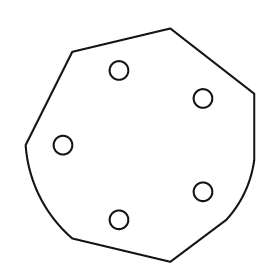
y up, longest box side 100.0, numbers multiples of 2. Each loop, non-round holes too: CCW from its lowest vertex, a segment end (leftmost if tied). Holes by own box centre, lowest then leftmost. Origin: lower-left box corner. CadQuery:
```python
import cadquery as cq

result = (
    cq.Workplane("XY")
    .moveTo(62.0, 0.0)
    .lineTo(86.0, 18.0)
    .threePointArc((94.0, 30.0), (98.0, 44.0))
    .lineTo(98.0, 72.0)
    .lineTo(62.0, 100.0)
    .lineTo(20.0, 90.0)
    .lineTo(0.0, 50.0)
    .threePointArc((6.0, 28.0), (20.0, 10.0))
    .close()
    .moveTo(40.0, 18.0)
    .circle(4.0)
    .moveTo(76.0, 30.0)
    .circle(4.0)
    .moveTo(16.0, 50.0)
    .circle(4.0)
    .moveTo(76.0, 70.0)
    .circle(4.0)
    .moveTo(40.0, 82.0)
    .circle(4.0)
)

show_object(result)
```